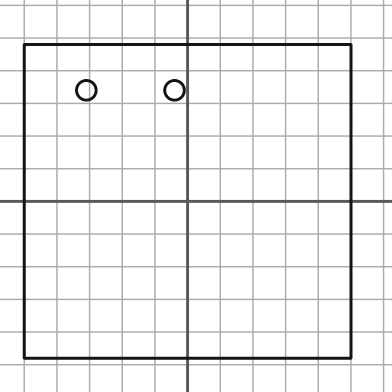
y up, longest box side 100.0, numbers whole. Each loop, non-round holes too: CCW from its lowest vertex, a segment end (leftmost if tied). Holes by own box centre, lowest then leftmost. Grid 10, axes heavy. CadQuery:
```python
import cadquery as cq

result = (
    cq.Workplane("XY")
    .moveTo(-50.0, -48.0)
    .lineTo(50.0, -48.0)
    .lineTo(50.0, 48.0)
    .lineTo(-50.0, 48.0)
    .close()
    .moveTo(-31.0, 34.0)
    .circle(3.0)
    .moveTo(-4.0, 34.0)
    .circle(3.0)
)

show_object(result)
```